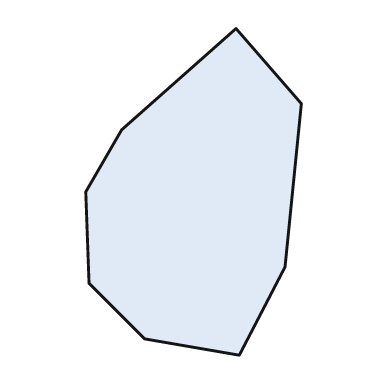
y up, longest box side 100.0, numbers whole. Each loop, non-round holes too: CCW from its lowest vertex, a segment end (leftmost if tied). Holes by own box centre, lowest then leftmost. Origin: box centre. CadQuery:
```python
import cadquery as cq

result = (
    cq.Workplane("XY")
    .moveTo(14.0, -50.0)
    .lineTo(28.0, -23.0)
    .lineTo(33.0, 27.0)
    .lineTo(13.0, 50.0)
    .lineTo(-22.0, 19.0)
    .lineTo(-33.0, 0.0)
    .lineTo(-32.0, -28.0)
    .lineTo(-15.0, -45.0)
    .close()
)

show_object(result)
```